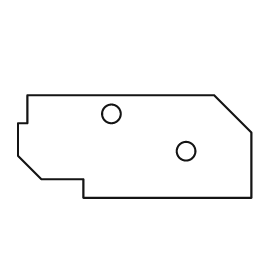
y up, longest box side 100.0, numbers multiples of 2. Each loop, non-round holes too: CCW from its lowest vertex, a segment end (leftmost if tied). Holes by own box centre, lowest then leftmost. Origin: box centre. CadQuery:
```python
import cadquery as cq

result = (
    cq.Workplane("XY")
    .moveTo(-22.0, -22.0)
    .lineTo(50.0, -22.0)
    .lineTo(50.0, 6.0)
    .lineTo(34.0, 22.0)
    .lineTo(-46.0, 22.0)
    .lineTo(-46.0, 10.0)
    .lineTo(-50.0, 10.0)
    .lineTo(-50.0, -4.0)
    .lineTo(-40.0, -14.0)
    .lineTo(-22.0, -14.0)
    .close()
    .moveTo(22.0, -2.0)
    .circle(4.0)
    .moveTo(-10.0, 14.0)
    .circle(4.0)
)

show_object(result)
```